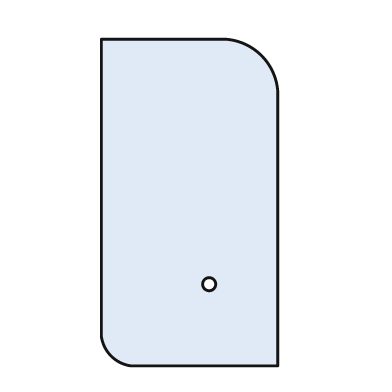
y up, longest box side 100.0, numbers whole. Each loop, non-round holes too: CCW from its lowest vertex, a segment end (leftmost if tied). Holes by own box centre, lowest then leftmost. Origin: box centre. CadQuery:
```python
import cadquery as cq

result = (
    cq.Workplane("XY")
    .moveTo(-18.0, -50.0)
    .lineTo(27.0, -50.0)
    .lineTo(27.0, 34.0)
    .threePointArc((22.0, 45.0), (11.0, 50.0))
    .lineTo(-27.0, 50.0)
    .lineTo(-27.0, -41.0)
    .threePointArc((-24.0, -47.0), (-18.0, -50.0))
    .close()
    .moveTo(6.0, -25.0)
    .circle(2.0)
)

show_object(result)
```